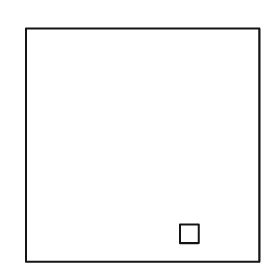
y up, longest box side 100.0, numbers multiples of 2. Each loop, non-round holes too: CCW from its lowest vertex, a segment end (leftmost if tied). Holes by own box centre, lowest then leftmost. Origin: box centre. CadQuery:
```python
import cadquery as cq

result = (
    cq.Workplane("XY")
    .moveTo(-50.0, -50.0)
    .lineTo(50.0, -50.0)
    .lineTo(50.0, 50.0)
    .lineTo(-50.0, 50.0)
    .close()
    .moveTo(16.0, -42.0)
    .lineTo(24.0, -42.0)
    .lineTo(24.0, -34.0)
    .lineTo(16.0, -34.0)
    .close()
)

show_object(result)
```